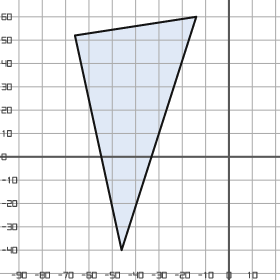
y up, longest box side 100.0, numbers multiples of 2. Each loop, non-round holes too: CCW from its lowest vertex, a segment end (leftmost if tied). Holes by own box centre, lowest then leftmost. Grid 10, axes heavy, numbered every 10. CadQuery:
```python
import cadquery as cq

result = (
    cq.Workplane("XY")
    .moveTo(-46.0, -40.0)
    .lineTo(-14.0, 60.0)
    .lineTo(-66.0, 52.0)
    .close()
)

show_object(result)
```